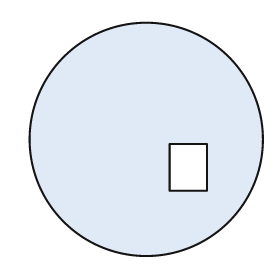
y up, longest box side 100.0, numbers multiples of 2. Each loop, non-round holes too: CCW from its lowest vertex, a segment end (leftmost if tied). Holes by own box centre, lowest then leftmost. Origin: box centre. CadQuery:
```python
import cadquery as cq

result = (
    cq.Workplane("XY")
    .moveTo(0.0, 0.0)
    .circle(50.0)
    .moveTo(10.0, -22.0)
    .lineTo(26.0, -22.0)
    .lineTo(26.0, -2.0)
    .lineTo(10.0, -2.0)
    .close()
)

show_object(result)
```